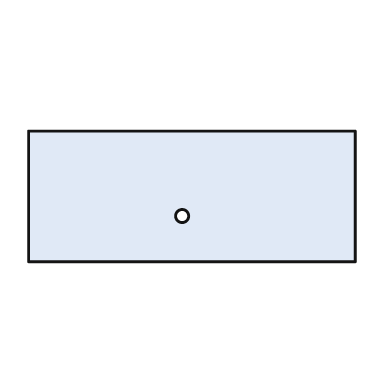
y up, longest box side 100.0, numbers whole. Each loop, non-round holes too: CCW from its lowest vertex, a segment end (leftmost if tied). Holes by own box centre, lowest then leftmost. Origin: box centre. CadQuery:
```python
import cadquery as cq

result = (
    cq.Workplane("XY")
    .moveTo(-50.0, -20.0)
    .lineTo(50.0, -20.0)
    .lineTo(50.0, 20.0)
    .lineTo(-50.0, 20.0)
    .close()
    .moveTo(-3.0, -6.0)
    .circle(2.0)
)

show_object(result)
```